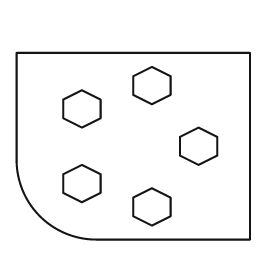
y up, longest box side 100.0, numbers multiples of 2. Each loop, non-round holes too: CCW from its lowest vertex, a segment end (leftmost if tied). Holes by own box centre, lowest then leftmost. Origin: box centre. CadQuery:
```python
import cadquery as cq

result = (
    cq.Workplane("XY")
    .moveTo(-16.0, -40.0)
    .lineTo(50.0, -40.0)
    .lineTo(50.0, 40.0)
    .lineTo(-50.0, 40.0)
    .lineTo(-50.0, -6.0)
    .threePointArc((-40.0, -30.0), (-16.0, -40.0))
    .close()
    .moveTo(8.0, -34.0)
    .lineTo(16.0, -30.0)
    .lineTo(16.0, -22.0)
    .lineTo(8.0, -18.0)
    .lineTo(0.0, -22.0)
    .lineTo(0.0, -30.0)
    .close()
    .moveTo(-22.0, -24.0)
    .lineTo(-14.0, -20.0)
    .lineTo(-14.0, -12.0)
    .lineTo(-22.0, -8.0)
    .lineTo(-30.0, -12.0)
    .lineTo(-30.0, -20.0)
    .close()
    .moveTo(28.0, -8.0)
    .lineTo(36.0, -4.0)
    .lineTo(36.0, 4.0)
    .lineTo(28.0, 8.0)
    .lineTo(20.0, 4.0)
    .lineTo(20.0, -4.0)
    .close()
    .moveTo(-22.0, 8.0)
    .lineTo(-14.0, 12.0)
    .lineTo(-14.0, 20.0)
    .lineTo(-22.0, 24.0)
    .lineTo(-30.0, 20.0)
    .lineTo(-30.0, 12.0)
    .close()
    .moveTo(8.0, 18.0)
    .lineTo(16.0, 22.0)
    .lineTo(16.0, 30.0)
    .lineTo(8.0, 34.0)
    .lineTo(0.0, 30.0)
    .lineTo(0.0, 22.0)
    .close()
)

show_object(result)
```